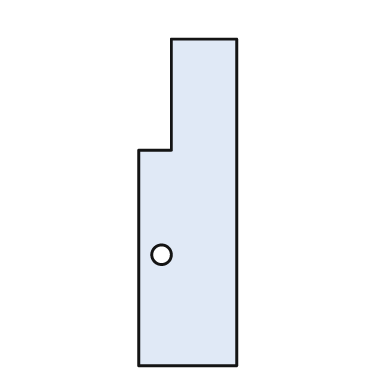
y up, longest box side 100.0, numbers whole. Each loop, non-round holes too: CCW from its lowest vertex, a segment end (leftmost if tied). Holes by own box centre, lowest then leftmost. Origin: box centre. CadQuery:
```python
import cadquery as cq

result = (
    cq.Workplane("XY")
    .moveTo(-15.0, -50.0)
    .lineTo(15.0, -50.0)
    .lineTo(15.0, 50.0)
    .lineTo(-5.0, 50.0)
    .lineTo(-5.0, 16.0)
    .lineTo(-15.0, 16.0)
    .close()
    .moveTo(-8.0, -16.0)
    .circle(3.0)
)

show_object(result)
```